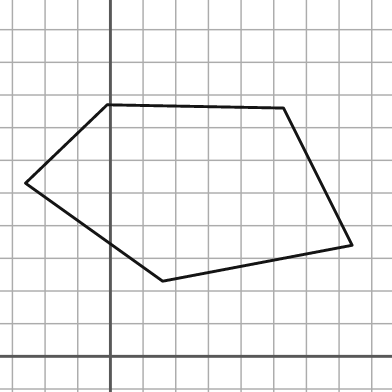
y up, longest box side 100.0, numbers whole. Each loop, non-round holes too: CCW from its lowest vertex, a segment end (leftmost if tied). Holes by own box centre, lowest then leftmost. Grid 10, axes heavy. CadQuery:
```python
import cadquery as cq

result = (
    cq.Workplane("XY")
    .moveTo(16.0, 23.0)
    .lineTo(74.0, 34.0)
    .lineTo(53.0, 76.0)
    .lineTo(-1.0, 77.0)
    .lineTo(-26.0, 53.0)
    .close()
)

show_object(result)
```